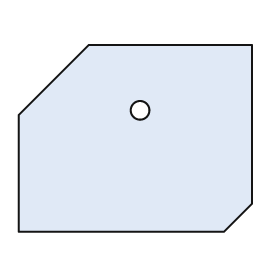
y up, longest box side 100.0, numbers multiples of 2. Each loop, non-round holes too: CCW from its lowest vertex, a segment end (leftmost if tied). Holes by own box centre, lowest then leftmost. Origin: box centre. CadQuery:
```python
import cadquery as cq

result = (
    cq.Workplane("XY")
    .moveTo(-50.0, -40.0)
    .lineTo(38.0, -40.0)
    .lineTo(50.0, -28.0)
    .lineTo(50.0, 40.0)
    .lineTo(-20.0, 40.0)
    .lineTo(-50.0, 10.0)
    .close()
    .moveTo(2.0, 12.0)
    .circle(4.0)
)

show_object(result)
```